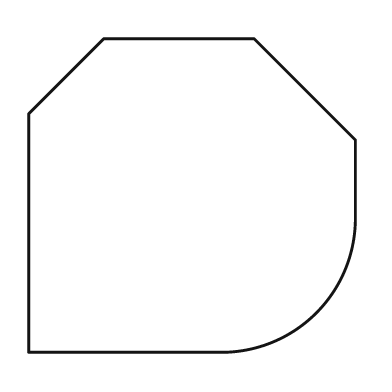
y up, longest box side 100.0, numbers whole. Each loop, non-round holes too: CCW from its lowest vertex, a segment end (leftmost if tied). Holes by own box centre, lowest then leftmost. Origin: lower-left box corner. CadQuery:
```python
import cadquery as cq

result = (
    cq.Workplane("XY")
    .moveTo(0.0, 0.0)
    .lineTo(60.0, 0.0)
    .threePointArc((88.0, 12.0), (100.0, 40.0))
    .lineTo(100.0, 65.0)
    .lineTo(69.0, 96.0)
    .lineTo(23.0, 96.0)
    .lineTo(0.0, 73.0)
    .close()
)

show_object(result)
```